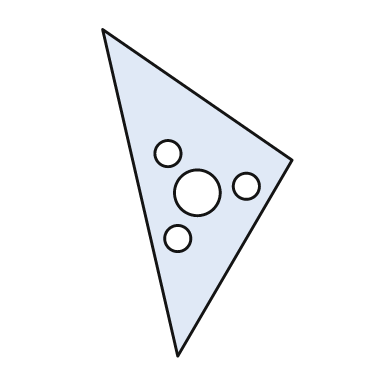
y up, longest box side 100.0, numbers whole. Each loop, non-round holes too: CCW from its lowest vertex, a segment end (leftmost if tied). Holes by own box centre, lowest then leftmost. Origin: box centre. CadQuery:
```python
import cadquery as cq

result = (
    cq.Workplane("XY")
    .moveTo(-6.0, -50.0)
    .lineTo(29.0, 10.0)
    .lineTo(-29.0, 50.0)
    .close()
    .moveTo(-6.0, -14.0)
    .circle(4.0)
    .moveTo(0.0, 0.0)
    .circle(7.0)
    .moveTo(15.0, 2.0)
    .circle(4.0)
    .moveTo(-9.0, 12.0)
    .circle(4.0)
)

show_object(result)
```